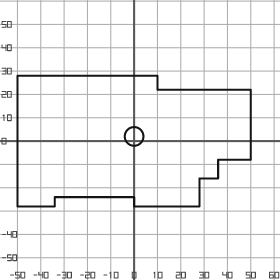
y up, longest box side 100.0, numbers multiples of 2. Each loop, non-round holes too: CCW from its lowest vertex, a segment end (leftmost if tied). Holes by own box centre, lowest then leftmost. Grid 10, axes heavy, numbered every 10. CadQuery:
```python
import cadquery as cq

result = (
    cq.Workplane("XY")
    .moveTo(-50.0, -28.0)
    .lineTo(-34.0, -28.0)
    .lineTo(-34.0, -24.0)
    .lineTo(0.0, -24.0)
    .lineTo(0.0, -28.0)
    .lineTo(28.0, -28.0)
    .lineTo(28.0, -16.0)
    .lineTo(36.0, -16.0)
    .lineTo(36.0, -8.0)
    .lineTo(50.0, -8.0)
    .lineTo(50.0, 22.0)
    .lineTo(10.0, 22.0)
    .lineTo(10.0, 28.0)
    .lineTo(-50.0, 28.0)
    .close()
    .moveTo(0.0, 2.0)
    .circle(4.0)
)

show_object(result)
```